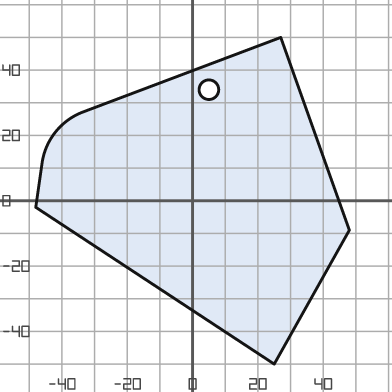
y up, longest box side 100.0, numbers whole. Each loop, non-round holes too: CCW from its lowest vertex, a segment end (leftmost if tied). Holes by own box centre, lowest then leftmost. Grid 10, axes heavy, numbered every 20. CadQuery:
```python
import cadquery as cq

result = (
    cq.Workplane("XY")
    .moveTo(25.0, -50.0)
    .lineTo(48.0, -9.0)
    .lineTo(27.0, 50.0)
    .lineTo(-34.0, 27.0)
    .threePointArc((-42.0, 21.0), (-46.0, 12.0))
    .lineTo(-48.0, -2.0)
    .close()
    .moveTo(5.0, 34.0)
    .circle(3.0)
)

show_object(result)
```